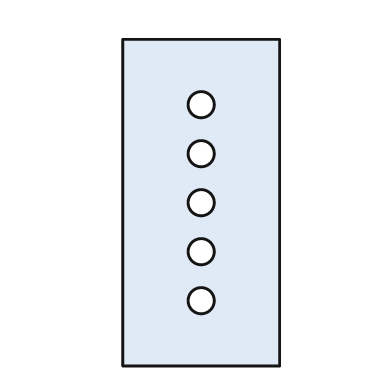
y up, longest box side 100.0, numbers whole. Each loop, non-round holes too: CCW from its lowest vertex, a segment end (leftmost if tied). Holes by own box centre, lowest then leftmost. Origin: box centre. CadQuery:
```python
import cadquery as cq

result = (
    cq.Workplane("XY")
    .moveTo(-24.0, -50.0)
    .lineTo(24.0, -50.0)
    .lineTo(24.0, 50.0)
    .lineTo(-24.0, 50.0)
    .close()
    .moveTo(0.0, -30.0)
    .circle(4.0)
    .moveTo(0.0, -15.0)
    .circle(4.0)
    .moveTo(0.0, 0.0)
    .circle(4.0)
    .moveTo(0.0, 15.0)
    .circle(4.0)
    .moveTo(0.0, 30.0)
    .circle(4.0)
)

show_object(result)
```